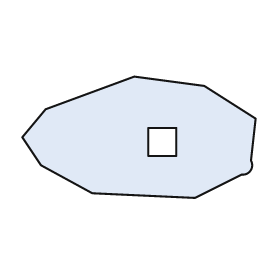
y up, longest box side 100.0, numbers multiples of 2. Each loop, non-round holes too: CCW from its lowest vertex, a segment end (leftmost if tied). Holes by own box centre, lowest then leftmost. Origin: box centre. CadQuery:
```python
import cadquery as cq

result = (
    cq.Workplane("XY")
    .moveTo(24.0, -26.0)
    .lineTo(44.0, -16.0)
    .threePointArc((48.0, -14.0), (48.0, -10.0))
    .lineTo(50.0, 8.0)
    .lineTo(28.0, 22.0)
    .lineTo(-2.0, 26.0)
    .lineTo(-40.0, 12.0)
    .lineTo(-50.0, 0.0)
    .lineTo(-42.0, -12.0)
    .lineTo(-20.0, -24.0)
    .close()
    .moveTo(4.0, -8.0)
    .lineTo(16.0, -8.0)
    .lineTo(16.0, 4.0)
    .lineTo(4.0, 4.0)
    .close()
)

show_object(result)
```